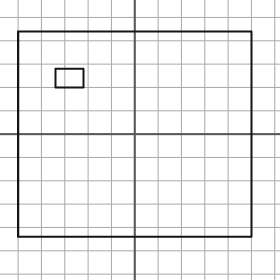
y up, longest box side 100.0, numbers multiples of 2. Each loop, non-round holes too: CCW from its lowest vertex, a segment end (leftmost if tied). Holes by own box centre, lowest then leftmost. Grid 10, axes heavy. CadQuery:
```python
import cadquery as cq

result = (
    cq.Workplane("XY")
    .moveTo(-50.0, -44.0)
    .lineTo(50.0, -44.0)
    .lineTo(50.0, 44.0)
    .lineTo(-50.0, 44.0)
    .close()
    .moveTo(-34.0, 20.0)
    .lineTo(-22.0, 20.0)
    .lineTo(-22.0, 28.0)
    .lineTo(-34.0, 28.0)
    .close()
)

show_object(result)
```